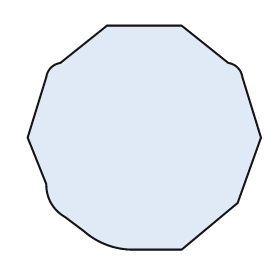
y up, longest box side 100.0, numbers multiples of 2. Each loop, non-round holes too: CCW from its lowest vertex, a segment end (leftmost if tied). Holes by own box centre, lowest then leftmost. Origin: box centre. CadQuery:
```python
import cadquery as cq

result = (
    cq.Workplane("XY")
    .moveTo(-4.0, -48.0)
    .lineTo(16.0, -48.0)
    .lineTo(40.0, -28.0)
    .lineTo(50.0, 0.0)
    .lineTo(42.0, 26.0)
    .threePointArc((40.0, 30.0), (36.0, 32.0))
    .lineTo(16.0, 48.0)
    .lineTo(-16.0, 48.0)
    .lineTo(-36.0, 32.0)
    .threePointArc((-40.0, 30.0), (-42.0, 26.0))
    .lineTo(-50.0, 0.0)
    .lineTo(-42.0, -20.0)
    .threePointArc((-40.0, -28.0), (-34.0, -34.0))
    .lineTo(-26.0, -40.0)
    .threePointArc((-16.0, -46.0), (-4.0, -48.0))
    .close()
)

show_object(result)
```